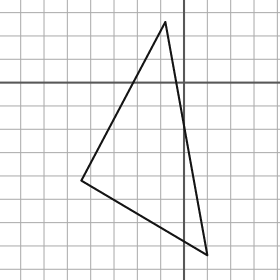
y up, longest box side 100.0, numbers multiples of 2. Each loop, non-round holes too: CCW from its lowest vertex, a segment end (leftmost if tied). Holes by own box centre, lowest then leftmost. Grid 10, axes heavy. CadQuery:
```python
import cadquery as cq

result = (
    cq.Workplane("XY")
    .moveTo(10.0, -74.0)
    .lineTo(-8.0, 26.0)
    .lineTo(-44.0, -42.0)
    .close()
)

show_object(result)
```